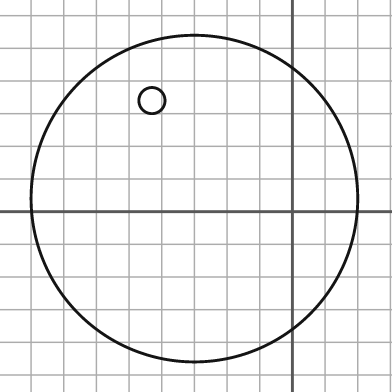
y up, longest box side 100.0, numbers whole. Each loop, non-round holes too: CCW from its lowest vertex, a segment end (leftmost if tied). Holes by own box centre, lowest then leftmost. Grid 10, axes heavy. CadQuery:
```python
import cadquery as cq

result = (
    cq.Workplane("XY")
    .moveTo(-30.0, 4.0)
    .circle(50.0)
    .moveTo(-43.0, 34.0)
    .circle(4.0)
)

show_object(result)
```